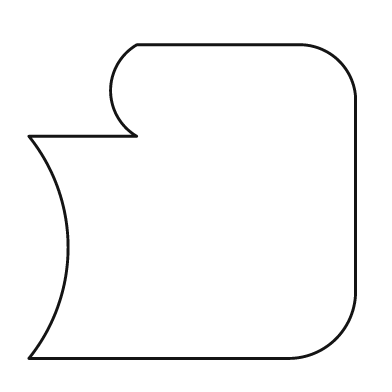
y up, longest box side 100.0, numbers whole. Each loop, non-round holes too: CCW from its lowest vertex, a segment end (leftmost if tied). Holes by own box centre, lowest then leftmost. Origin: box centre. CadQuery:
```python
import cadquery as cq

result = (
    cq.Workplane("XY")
    .moveTo(-50.0, -48.0)
    .lineTo(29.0, -48.0)
    .threePointArc((44.0, -42.0), (50.0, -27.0))
    .lineTo(50.0, 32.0)
    .threePointArc((45.0, 43.0), (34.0, 48.0))
    .lineTo(-17.0, 48.0)
    .threePointArc((-25.0, 34.0), (-17.0, 20.0))
    .lineTo(-50.0, 20.0)
    .threePointArc((-38.0, -14.0), (-50.0, -48.0))
    .close()
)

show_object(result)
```